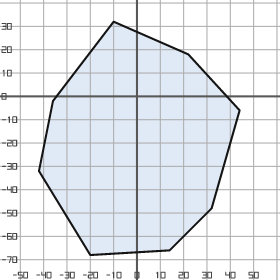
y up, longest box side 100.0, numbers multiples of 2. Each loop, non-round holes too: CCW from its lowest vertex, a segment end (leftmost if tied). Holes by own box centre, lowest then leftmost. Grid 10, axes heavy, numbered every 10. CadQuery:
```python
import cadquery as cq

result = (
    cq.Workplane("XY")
    .moveTo(-20.0, -68.0)
    .lineTo(14.0, -66.0)
    .lineTo(32.0, -48.0)
    .lineTo(44.0, -6.0)
    .lineTo(22.0, 18.0)
    .lineTo(-10.0, 32.0)
    .lineTo(-36.0, -2.0)
    .lineTo(-42.0, -32.0)
    .close()
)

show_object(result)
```